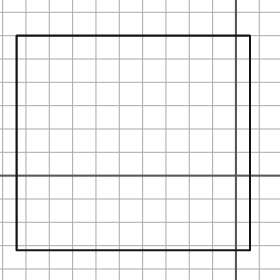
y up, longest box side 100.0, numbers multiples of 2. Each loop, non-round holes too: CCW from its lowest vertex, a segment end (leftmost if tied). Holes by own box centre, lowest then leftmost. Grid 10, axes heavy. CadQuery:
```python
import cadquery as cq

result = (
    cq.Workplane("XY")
    .moveTo(-94.0, -32.0)
    .lineTo(6.0, -32.0)
    .lineTo(6.0, 60.0)
    .lineTo(-94.0, 60.0)
    .close()
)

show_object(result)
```